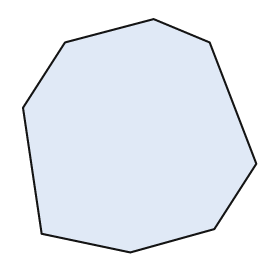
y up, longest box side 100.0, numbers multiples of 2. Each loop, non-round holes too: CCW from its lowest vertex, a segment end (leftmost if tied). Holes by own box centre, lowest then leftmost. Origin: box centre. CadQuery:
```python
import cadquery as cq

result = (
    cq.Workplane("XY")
    .moveTo(-4.0, -50.0)
    .lineTo(32.0, -40.0)
    .lineTo(50.0, -12.0)
    .lineTo(30.0, 40.0)
    .lineTo(6.0, 50.0)
    .lineTo(-32.0, 40.0)
    .lineTo(-50.0, 12.0)
    .lineTo(-42.0, -42.0)
    .close()
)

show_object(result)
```